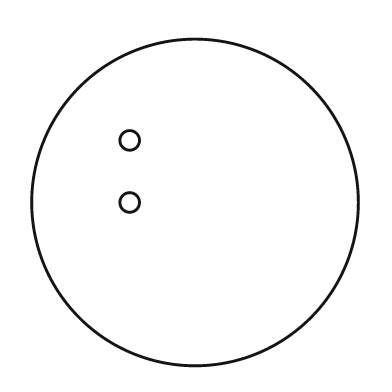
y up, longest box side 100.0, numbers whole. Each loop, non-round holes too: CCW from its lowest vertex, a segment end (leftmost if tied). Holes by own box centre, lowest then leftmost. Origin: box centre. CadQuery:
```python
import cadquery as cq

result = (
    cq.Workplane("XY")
    .moveTo(0.0, 0.0)
    .circle(50.0)
    .moveTo(-20.0, 0.0)
    .circle(3.0)
    .moveTo(-20.0, 19.0)
    .circle(3.0)
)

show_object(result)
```